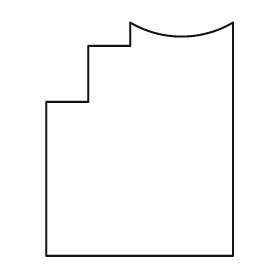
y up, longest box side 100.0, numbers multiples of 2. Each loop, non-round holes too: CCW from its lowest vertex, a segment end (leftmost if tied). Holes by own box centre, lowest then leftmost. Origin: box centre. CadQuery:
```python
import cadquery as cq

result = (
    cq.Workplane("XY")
    .moveTo(-40.0, -50.0)
    .lineTo(40.0, -50.0)
    .lineTo(40.0, 50.0)
    .threePointArc((18.0, 44.0), (-4.0, 50.0))
    .lineTo(-4.0, 40.0)
    .lineTo(-22.0, 40.0)
    .lineTo(-22.0, 16.0)
    .lineTo(-40.0, 16.0)
    .close()
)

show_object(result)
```